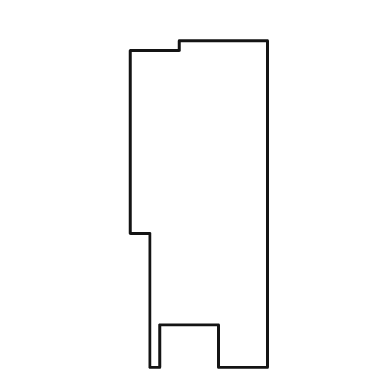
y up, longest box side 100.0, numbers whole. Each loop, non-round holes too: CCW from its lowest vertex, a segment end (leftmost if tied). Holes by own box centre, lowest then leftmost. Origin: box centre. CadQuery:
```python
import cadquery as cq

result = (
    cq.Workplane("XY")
    .moveTo(-15.0, -50.0)
    .lineTo(-12.0, -50.0)
    .lineTo(-12.0, -37.0)
    .lineTo(6.0, -37.0)
    .lineTo(6.0, -50.0)
    .lineTo(21.0, -50.0)
    .lineTo(21.0, 50.0)
    .lineTo(-6.0, 50.0)
    .lineTo(-6.0, 47.0)
    .lineTo(-21.0, 47.0)
    .lineTo(-21.0, -9.0)
    .lineTo(-15.0, -9.0)
    .close()
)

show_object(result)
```